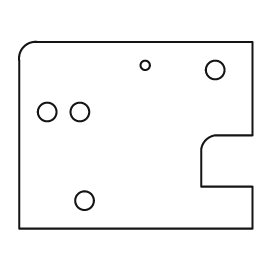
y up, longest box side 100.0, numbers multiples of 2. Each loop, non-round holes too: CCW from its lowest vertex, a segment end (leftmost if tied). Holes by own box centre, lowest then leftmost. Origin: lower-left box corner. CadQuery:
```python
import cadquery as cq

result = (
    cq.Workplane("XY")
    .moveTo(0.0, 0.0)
    .lineTo(100.0, 0.0)
    .lineTo(100.0, 18.0)
    .lineTo(78.0, 18.0)
    .lineTo(78.0, 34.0)
    .threePointArc((80.0, 38.0), (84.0, 40.0))
    .lineTo(100.0, 40.0)
    .lineTo(100.0, 80.0)
    .lineTo(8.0, 80.0)
    .threePointArc((2.0, 78.0), (0.0, 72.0))
    .close()
    .moveTo(28.0, 12.0)
    .circle(4.0)
    .moveTo(12.0, 50.0)
    .circle(4.0)
    .moveTo(26.0, 50.0)
    .circle(4.0)
    .moveTo(84.0, 68.0)
    .circle(4.0)
    .moveTo(54.0, 70.0)
    .circle(2.0)
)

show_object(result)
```